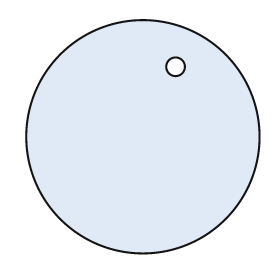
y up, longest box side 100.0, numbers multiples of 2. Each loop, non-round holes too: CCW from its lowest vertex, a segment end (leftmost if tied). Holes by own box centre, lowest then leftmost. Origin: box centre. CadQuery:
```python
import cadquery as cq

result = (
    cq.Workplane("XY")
    .moveTo(0.0, 0.0)
    .circle(50.0)
    .moveTo(14.0, 30.0)
    .circle(4.0)
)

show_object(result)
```